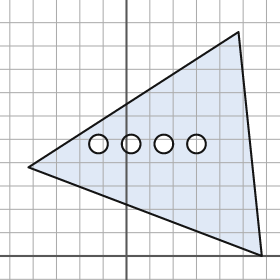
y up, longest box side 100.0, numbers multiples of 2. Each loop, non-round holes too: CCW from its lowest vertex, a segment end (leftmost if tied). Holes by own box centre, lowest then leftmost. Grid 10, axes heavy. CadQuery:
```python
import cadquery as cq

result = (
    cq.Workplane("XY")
    .moveTo(58.0, 0.0)
    .lineTo(48.0, 96.0)
    .lineTo(-42.0, 38.0)
    .close()
    .moveTo(-12.0, 48.0)
    .circle(4.0)
    .moveTo(2.0, 48.0)
    .circle(4.0)
    .moveTo(16.0, 48.0)
    .circle(4.0)
    .moveTo(30.0, 48.0)
    .circle(4.0)
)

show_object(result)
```